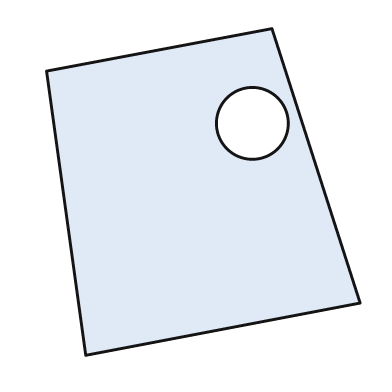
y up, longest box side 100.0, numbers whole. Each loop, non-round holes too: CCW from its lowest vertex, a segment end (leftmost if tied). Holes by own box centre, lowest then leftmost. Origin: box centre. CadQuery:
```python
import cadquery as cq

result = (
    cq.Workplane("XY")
    .moveTo(-36.0, -50.0)
    .lineTo(48.0, -34.0)
    .lineTo(21.0, 50.0)
    .lineTo(-48.0, 37.0)
    .close()
    .moveTo(15.0, 21.0)
    .circle(11.0)
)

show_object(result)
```